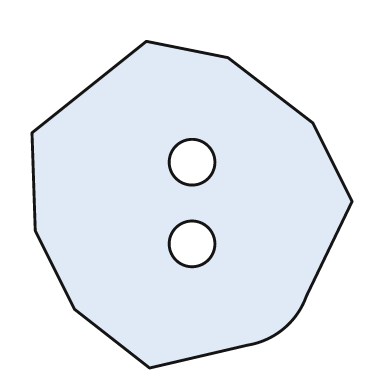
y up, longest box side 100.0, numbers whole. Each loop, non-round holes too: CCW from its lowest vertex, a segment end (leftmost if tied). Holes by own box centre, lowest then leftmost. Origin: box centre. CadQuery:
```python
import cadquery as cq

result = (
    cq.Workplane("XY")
    .moveTo(-13.0, -50.0)
    .lineTo(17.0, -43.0)
    .threePointArc((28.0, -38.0), (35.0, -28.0))
    .lineTo(49.0, 1.0)
    .lineTo(37.0, 25.0)
    .lineTo(11.0, 45.0)
    .lineTo(-14.0, 50.0)
    .lineTo(-49.0, 22.0)
    .lineTo(-48.0, -8.0)
    .lineTo(-36.0, -32.0)
    .close()
    .moveTo(0.0, -12.0)
    .circle(7.0)
    .moveTo(0.0, 13.0)
    .circle(7.0)
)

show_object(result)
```